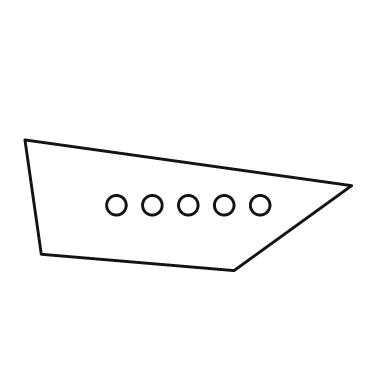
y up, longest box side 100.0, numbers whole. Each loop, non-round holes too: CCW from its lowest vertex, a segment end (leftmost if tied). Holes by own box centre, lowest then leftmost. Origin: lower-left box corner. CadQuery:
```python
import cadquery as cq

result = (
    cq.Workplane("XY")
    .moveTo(64.0, 0.0)
    .lineTo(100.0, 26.0)
    .lineTo(0.0, 40.0)
    .lineTo(5.0, 5.0)
    .close()
    .moveTo(28.0, 20.0)
    .circle(3.0)
    .moveTo(39.0, 20.0)
    .circle(3.0)
    .moveTo(50.0, 20.0)
    .circle(3.0)
    .moveTo(61.0, 20.0)
    .circle(3.0)
    .moveTo(72.0, 20.0)
    .circle(3.0)
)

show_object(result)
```